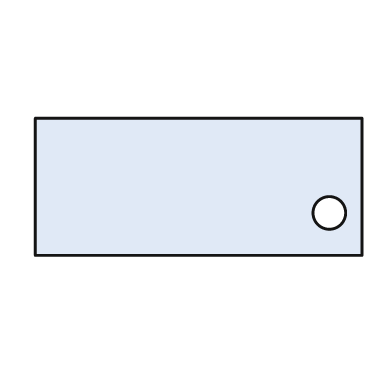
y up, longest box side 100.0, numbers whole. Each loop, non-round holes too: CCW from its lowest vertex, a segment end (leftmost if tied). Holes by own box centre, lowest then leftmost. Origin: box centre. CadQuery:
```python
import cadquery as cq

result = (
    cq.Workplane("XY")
    .moveTo(-50.0, -21.0)
    .lineTo(50.0, -21.0)
    .lineTo(50.0, 21.0)
    .lineTo(-50.0, 21.0)
    .close()
    .moveTo(40.0, -8.0)
    .circle(5.0)
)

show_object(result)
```